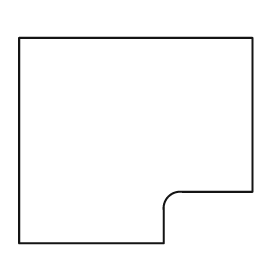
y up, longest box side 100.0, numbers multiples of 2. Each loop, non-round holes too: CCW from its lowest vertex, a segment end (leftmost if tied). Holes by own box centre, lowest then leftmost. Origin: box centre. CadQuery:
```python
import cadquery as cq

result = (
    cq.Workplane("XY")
    .moveTo(-50.0, -44.0)
    .lineTo(12.0, -44.0)
    .lineTo(12.0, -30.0)
    .threePointArc((14.0, -24.0), (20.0, -22.0))
    .lineTo(50.0, -22.0)
    .lineTo(50.0, 44.0)
    .lineTo(-50.0, 44.0)
    .close()
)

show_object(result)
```